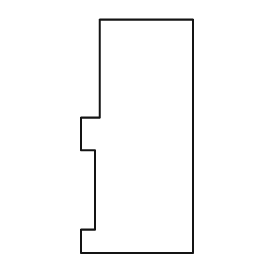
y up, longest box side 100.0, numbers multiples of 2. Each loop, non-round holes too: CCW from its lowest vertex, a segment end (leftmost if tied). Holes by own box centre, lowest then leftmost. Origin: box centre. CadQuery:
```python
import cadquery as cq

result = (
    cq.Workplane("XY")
    .moveTo(-24.0, -50.0)
    .lineTo(24.0, -50.0)
    .lineTo(24.0, 50.0)
    .lineTo(-16.0, 50.0)
    .lineTo(-16.0, 8.0)
    .lineTo(-24.0, 8.0)
    .lineTo(-24.0, -6.0)
    .lineTo(-18.0, -6.0)
    .lineTo(-18.0, -40.0)
    .lineTo(-24.0, -40.0)
    .close()
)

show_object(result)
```